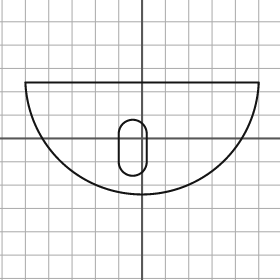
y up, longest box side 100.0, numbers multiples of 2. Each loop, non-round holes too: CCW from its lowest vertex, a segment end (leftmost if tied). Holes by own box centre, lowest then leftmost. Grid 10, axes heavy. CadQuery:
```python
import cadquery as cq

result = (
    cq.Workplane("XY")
    .moveTo(-50.0, 24.0)
    .threePointArc((0.0, -24.0), (50.0, 24.0))
    .close()
    .moveTo(-10.0, -10.0)
    .threePointArc((-4.0, -16.0), (2.0, -10.0))
    .lineTo(2.0, 2.0)
    .threePointArc((-4.0, 8.0), (-10.0, 2.0))
    .close()
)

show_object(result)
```